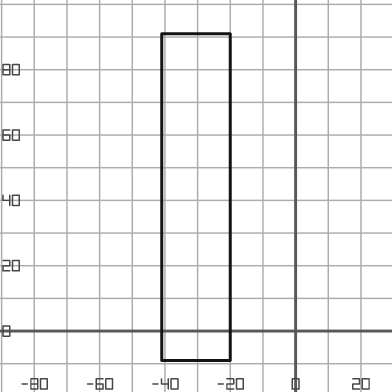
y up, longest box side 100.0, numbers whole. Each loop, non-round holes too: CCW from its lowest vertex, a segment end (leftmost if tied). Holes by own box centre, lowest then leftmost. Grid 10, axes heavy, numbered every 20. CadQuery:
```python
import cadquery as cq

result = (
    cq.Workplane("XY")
    .moveTo(-41.0, -9.0)
    .lineTo(-20.0, -9.0)
    .lineTo(-20.0, 91.0)
    .lineTo(-41.0, 91.0)
    .close()
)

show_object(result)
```